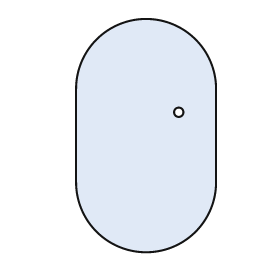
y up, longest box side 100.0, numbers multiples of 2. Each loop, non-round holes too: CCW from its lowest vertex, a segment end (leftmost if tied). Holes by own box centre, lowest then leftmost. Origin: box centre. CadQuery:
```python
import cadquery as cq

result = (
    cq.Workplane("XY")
    .moveTo(-30.0, -20.0)
    .threePointArc((0.0, -50.0), (30.0, -20.0))
    .lineTo(30.0, 20.0)
    .threePointArc((0.0, 50.0), (-30.0, 20.0))
    .close()
    .moveTo(14.0, 10.0)
    .circle(2.0)
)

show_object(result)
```